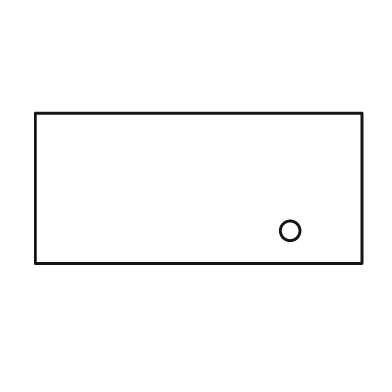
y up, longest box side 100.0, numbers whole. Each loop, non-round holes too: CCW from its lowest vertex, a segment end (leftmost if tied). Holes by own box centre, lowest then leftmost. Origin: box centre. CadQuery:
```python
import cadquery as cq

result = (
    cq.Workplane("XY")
    .moveTo(-50.0, -23.0)
    .lineTo(50.0, -23.0)
    .lineTo(50.0, 23.0)
    .lineTo(-50.0, 23.0)
    .close()
    .moveTo(28.0, -13.0)
    .circle(3.0)
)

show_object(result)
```